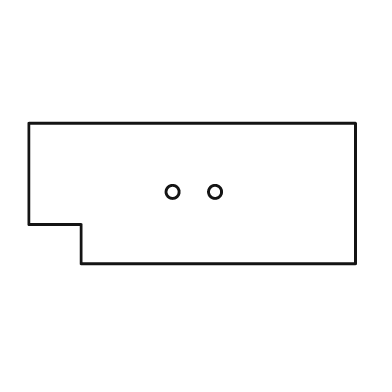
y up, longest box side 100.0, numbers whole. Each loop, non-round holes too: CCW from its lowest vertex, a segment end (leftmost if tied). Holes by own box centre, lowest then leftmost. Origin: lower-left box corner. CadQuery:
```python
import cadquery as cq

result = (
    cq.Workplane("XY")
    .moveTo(16.0, 0.0)
    .lineTo(100.0, 0.0)
    .lineTo(100.0, 43.0)
    .lineTo(0.0, 43.0)
    .lineTo(0.0, 12.0)
    .lineTo(16.0, 12.0)
    .close()
    .moveTo(44.0, 22.0)
    .circle(2.0)
    .moveTo(57.0, 22.0)
    .circle(2.0)
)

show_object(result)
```